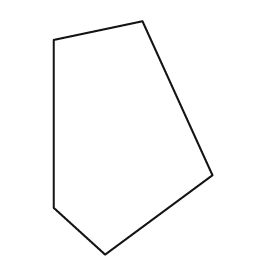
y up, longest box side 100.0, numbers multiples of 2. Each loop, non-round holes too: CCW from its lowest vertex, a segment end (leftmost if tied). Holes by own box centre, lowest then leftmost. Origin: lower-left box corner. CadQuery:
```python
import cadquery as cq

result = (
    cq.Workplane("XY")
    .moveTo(22.0, 0.0)
    .lineTo(68.0, 34.0)
    .lineTo(38.0, 100.0)
    .lineTo(0.0, 92.0)
    .lineTo(0.0, 20.0)
    .close()
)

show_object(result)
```